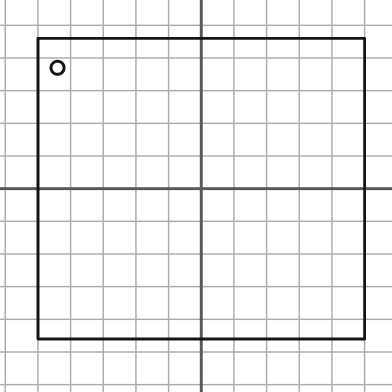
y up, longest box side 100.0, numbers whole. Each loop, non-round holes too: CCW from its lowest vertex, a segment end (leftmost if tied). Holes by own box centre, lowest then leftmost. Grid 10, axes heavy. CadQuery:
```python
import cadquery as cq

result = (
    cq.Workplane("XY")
    .moveTo(-50.0, -46.0)
    .lineTo(50.0, -46.0)
    .lineTo(50.0, 46.0)
    .lineTo(-50.0, 46.0)
    .close()
    .moveTo(-44.0, 37.0)
    .circle(2.0)
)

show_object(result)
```